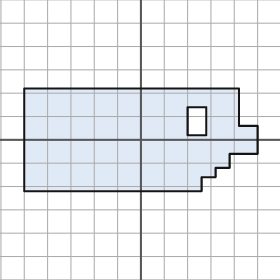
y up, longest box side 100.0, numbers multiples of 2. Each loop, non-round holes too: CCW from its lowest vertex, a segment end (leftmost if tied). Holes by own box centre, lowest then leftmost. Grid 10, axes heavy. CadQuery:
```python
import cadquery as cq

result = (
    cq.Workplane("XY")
    .moveTo(-50.0, -22.0)
    .lineTo(26.0, -22.0)
    .lineTo(26.0, -16.0)
    .lineTo(32.0, -16.0)
    .lineTo(32.0, -12.0)
    .lineTo(38.0, -12.0)
    .lineTo(38.0, -6.0)
    .lineTo(50.0, -6.0)
    .lineTo(50.0, 6.0)
    .lineTo(42.0, 6.0)
    .lineTo(42.0, 22.0)
    .lineTo(-50.0, 22.0)
    .close()
    .moveTo(20.0, 2.0)
    .lineTo(28.0, 2.0)
    .lineTo(28.0, 14.0)
    .lineTo(20.0, 14.0)
    .close()
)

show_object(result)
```